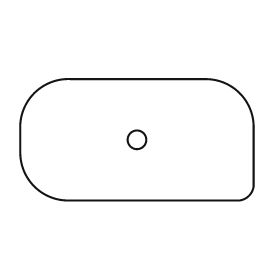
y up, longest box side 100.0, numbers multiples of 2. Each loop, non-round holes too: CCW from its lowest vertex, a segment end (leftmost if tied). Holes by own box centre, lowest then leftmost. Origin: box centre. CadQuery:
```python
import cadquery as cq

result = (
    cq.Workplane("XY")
    .moveTo(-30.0, -26.0)
    .lineTo(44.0, -26.0)
    .threePointArc((48.0, -24.0), (50.0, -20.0))
    .lineTo(50.0, 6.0)
    .threePointArc((44.0, 20.0), (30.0, 26.0))
    .lineTo(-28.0, 26.0)
    .threePointArc((-44.0, 20.0), (-50.0, 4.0))
    .lineTo(-50.0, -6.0)
    .threePointArc((-44.0, -20.0), (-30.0, -26.0))
    .close()
    .moveTo(0.0, 0.0)
    .circle(4.0)
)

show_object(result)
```